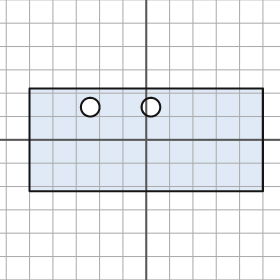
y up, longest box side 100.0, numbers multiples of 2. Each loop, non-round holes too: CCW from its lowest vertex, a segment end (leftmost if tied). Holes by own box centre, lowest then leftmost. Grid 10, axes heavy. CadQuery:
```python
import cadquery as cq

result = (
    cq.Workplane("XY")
    .moveTo(-50.0, -22.0)
    .lineTo(50.0, -22.0)
    .lineTo(50.0, 22.0)
    .lineTo(-50.0, 22.0)
    .close()
    .moveTo(-24.0, 14.0)
    .circle(4.0)
    .moveTo(2.0, 14.0)
    .circle(4.0)
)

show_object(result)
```